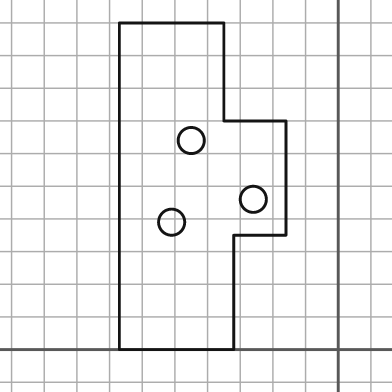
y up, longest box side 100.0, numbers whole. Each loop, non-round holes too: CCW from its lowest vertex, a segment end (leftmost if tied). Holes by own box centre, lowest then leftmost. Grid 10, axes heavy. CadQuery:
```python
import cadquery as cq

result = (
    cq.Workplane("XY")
    .moveTo(-67.0, 0.0)
    .lineTo(-32.0, 0.0)
    .lineTo(-32.0, 35.0)
    .lineTo(-16.0, 35.0)
    .lineTo(-16.0, 70.0)
    .lineTo(-35.0, 70.0)
    .lineTo(-35.0, 100.0)
    .lineTo(-67.0, 100.0)
    .close()
    .moveTo(-51.0, 39.0)
    .circle(4.0)
    .moveTo(-26.0, 46.0)
    .circle(4.0)
    .moveTo(-45.0, 64.0)
    .circle(4.0)
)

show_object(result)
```